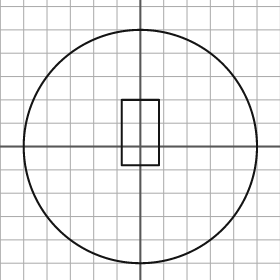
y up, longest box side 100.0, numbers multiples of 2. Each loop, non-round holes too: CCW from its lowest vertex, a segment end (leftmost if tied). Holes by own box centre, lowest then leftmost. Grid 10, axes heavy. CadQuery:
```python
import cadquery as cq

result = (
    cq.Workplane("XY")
    .moveTo(0.0, 0.0)
    .circle(50.0)
    .moveTo(-8.0, -8.0)
    .lineTo(8.0, -8.0)
    .lineTo(8.0, 20.0)
    .lineTo(-8.0, 20.0)
    .close()
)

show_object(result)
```